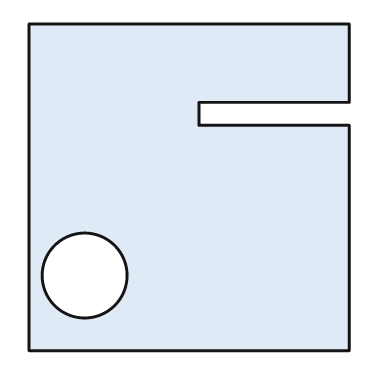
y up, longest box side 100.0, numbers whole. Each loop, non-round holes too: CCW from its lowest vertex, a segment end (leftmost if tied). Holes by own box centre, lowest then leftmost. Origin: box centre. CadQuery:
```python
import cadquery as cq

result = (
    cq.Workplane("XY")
    .moveTo(-49.0, -50.0)
    .lineTo(49.0, -50.0)
    .lineTo(49.0, 19.0)
    .lineTo(3.0, 19.0)
    .lineTo(3.0, 26.0)
    .lineTo(49.0, 26.0)
    .lineTo(49.0, 50.0)
    .lineTo(-49.0, 50.0)
    .close()
    .moveTo(-32.0, -27.0)
    .circle(13.0)
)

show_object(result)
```